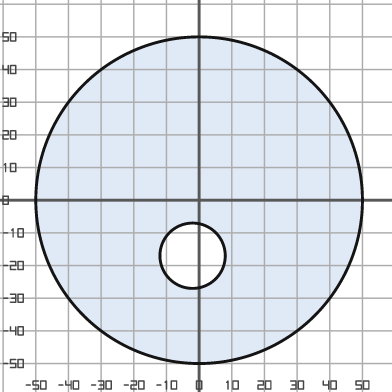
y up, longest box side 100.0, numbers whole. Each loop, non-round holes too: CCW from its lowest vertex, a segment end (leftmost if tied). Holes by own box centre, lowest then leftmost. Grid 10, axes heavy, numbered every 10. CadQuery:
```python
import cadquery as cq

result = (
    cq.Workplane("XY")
    .moveTo(0.0, 0.0)
    .circle(50.0)
    .moveTo(-2.0, -17.0)
    .circle(10.0)
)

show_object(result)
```